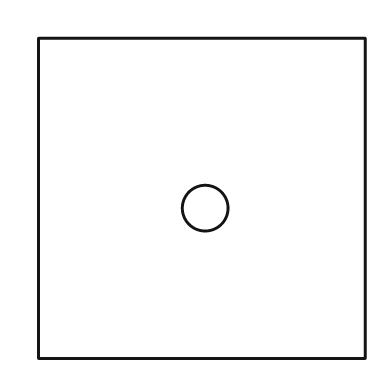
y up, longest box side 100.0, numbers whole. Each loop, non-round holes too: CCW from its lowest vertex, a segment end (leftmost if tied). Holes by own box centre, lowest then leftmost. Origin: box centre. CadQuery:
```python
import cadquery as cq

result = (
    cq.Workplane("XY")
    .moveTo(-50.0, -49.0)
    .lineTo(50.0, -49.0)
    .lineTo(50.0, 49.0)
    .lineTo(-50.0, 49.0)
    .close()
    .moveTo(1.0, -3.0)
    .circle(7.0)
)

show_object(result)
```